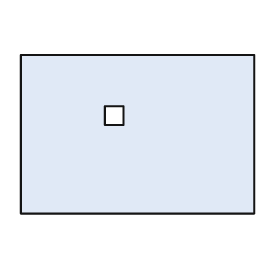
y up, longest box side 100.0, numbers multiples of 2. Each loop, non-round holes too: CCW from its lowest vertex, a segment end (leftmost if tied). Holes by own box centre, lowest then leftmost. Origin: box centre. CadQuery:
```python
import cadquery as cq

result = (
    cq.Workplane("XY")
    .moveTo(-50.0, -34.0)
    .lineTo(50.0, -34.0)
    .lineTo(50.0, 34.0)
    .lineTo(-50.0, 34.0)
    .close()
    .moveTo(-14.0, 4.0)
    .lineTo(-6.0, 4.0)
    .lineTo(-6.0, 12.0)
    .lineTo(-14.0, 12.0)
    .close()
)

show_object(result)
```